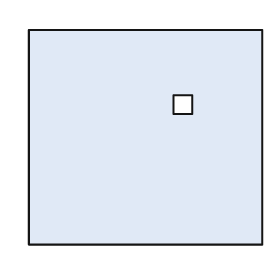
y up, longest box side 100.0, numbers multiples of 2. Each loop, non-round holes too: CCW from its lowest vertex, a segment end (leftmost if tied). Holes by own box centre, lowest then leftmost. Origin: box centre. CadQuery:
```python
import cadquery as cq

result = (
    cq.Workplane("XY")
    .moveTo(-50.0, -46.0)
    .lineTo(50.0, -46.0)
    .lineTo(50.0, 46.0)
    .lineTo(-50.0, 46.0)
    .close()
    .moveTo(12.0, 10.0)
    .lineTo(20.0, 10.0)
    .lineTo(20.0, 18.0)
    .lineTo(12.0, 18.0)
    .close()
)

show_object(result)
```